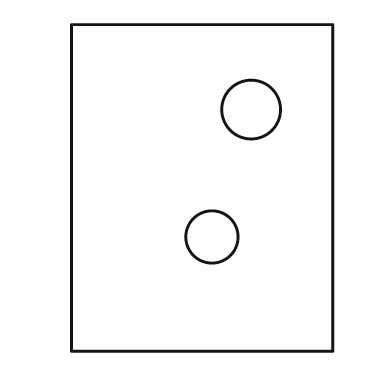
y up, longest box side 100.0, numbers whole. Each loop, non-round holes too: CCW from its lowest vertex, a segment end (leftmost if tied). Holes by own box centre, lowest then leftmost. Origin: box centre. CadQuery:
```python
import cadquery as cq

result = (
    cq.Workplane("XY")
    .moveTo(-40.0, -50.0)
    .lineTo(40.0, -50.0)
    .lineTo(40.0, 50.0)
    .lineTo(-40.0, 50.0)
    .close()
    .moveTo(3.0, -15.0)
    .circle(8.0)
    .moveTo(15.0, 24.0)
    .circle(9.0)
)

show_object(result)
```